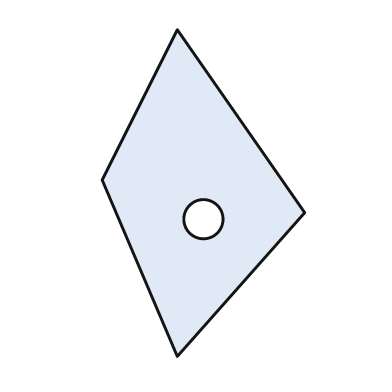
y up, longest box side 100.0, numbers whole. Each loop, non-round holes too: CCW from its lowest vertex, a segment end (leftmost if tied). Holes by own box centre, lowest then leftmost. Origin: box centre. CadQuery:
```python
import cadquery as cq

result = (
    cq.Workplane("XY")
    .moveTo(-8.0, -50.0)
    .lineTo(31.0, -6.0)
    .lineTo(-8.0, 50.0)
    .lineTo(-31.0, 4.0)
    .close()
    .moveTo(0.0, -8.0)
    .circle(6.0)
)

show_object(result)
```